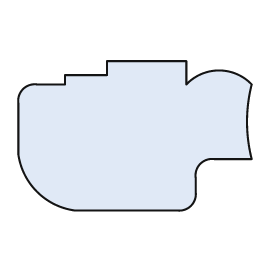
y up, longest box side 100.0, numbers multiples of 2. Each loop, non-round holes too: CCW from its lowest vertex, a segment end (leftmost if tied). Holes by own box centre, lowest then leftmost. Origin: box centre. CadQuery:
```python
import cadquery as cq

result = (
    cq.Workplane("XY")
    .moveTo(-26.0, -32.0)
    .lineTo(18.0, -32.0)
    .threePointArc((24.0, -30.0), (26.0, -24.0))
    .lineTo(26.0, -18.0)
    .threePointArc((28.0, -12.0), (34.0, -10.0))
    .lineTo(50.0, -10.0)
    .threePointArc((48.0, 6.0), (50.0, 22.0))
    .threePointArc((36.0, 28.0), (22.0, 22.0))
    .lineTo(22.0, 32.0)
    .lineTo(-12.0, 32.0)
    .lineTo(-12.0, 26.0)
    .lineTo(-30.0, 26.0)
    .lineTo(-30.0, 22.0)
    .lineTo(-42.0, 22.0)
    .threePointArc((-48.0, 20.0), (-50.0, 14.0))
    .lineTo(-50.0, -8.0)
    .threePointArc((-42.0, -24.0), (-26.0, -32.0))
    .close()
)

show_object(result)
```